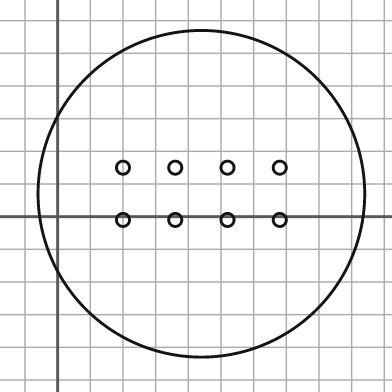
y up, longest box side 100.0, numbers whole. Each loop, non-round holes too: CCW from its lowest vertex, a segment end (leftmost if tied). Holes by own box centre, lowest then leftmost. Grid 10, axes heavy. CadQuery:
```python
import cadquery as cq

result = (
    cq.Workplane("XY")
    .moveTo(44.0, 7.0)
    .circle(50.0)
    .moveTo(20.0, -1.0)
    .circle(2.0)
    .moveTo(36.0, -1.0)
    .circle(2.0)
    .moveTo(52.0, -1.0)
    .circle(2.0)
    .moveTo(68.0, -1.0)
    .circle(2.0)
    .moveTo(20.0, 15.0)
    .circle(2.0)
    .moveTo(36.0, 15.0)
    .circle(2.0)
    .moveTo(52.0, 15.0)
    .circle(2.0)
    .moveTo(68.0, 15.0)
    .circle(2.0)
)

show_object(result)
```